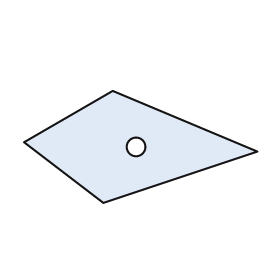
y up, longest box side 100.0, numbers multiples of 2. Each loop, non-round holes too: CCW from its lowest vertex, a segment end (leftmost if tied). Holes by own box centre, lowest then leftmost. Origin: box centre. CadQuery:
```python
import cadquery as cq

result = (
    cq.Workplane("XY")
    .moveTo(-16.0, -24.0)
    .lineTo(50.0, -2.0)
    .lineTo(-12.0, 24.0)
    .lineTo(-50.0, 2.0)
    .close()
    .moveTo(-2.0, 0.0)
    .circle(4.0)
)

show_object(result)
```